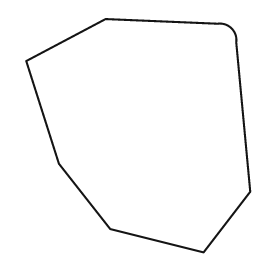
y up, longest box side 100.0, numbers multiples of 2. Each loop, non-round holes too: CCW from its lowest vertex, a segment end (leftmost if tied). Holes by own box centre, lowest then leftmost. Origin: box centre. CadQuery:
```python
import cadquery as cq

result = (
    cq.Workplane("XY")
    .moveTo(28.0, -50.0)
    .lineTo(48.0, -24.0)
    .lineTo(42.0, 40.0)
    .threePointArc((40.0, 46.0), (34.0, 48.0))
    .lineTo(-14.0, 50.0)
    .lineTo(-48.0, 32.0)
    .lineTo(-34.0, -12.0)
    .lineTo(-12.0, -40.0)
    .close()
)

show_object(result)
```